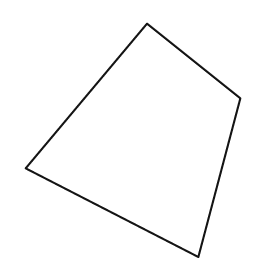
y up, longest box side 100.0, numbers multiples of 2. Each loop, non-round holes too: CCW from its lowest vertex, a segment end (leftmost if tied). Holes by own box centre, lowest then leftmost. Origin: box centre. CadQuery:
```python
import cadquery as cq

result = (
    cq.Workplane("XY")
    .moveTo(28.0, -50.0)
    .lineTo(46.0, 18.0)
    .lineTo(6.0, 50.0)
    .lineTo(-46.0, -12.0)
    .close()
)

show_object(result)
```